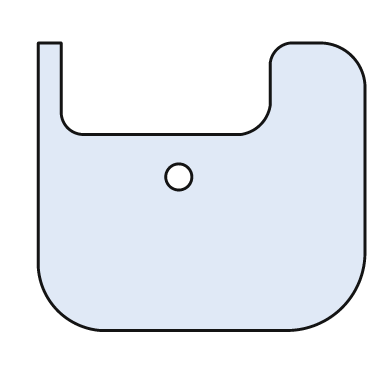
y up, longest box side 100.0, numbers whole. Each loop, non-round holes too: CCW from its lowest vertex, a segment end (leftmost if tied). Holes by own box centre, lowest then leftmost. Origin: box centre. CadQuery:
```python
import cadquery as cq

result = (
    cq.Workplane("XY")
    .moveTo(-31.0, -44.0)
    .lineTo(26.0, -44.0)
    .threePointArc((43.0, -37.0), (50.0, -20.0))
    .lineTo(50.0, 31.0)
    .threePointArc((46.0, 40.0), (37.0, 44.0))
    .lineTo(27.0, 44.0)
    .threePointArc((23.0, 42.0), (21.0, 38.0))
    .lineTo(21.0, 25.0)
    .threePointArc((18.0, 19.0), (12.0, 16.0))
    .lineTo(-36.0, 16.0)
    .threePointArc((-41.0, 18.0), (-43.0, 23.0))
    .lineTo(-43.0, 44.0)
    .lineTo(-50.0, 44.0)
    .lineTo(-50.0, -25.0)
    .threePointArc((-44.0, -38.0), (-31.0, -44.0))
    .close()
    .moveTo(-7.0, 3.0)
    .circle(4.0)
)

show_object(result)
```